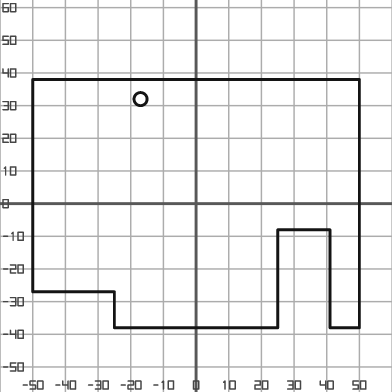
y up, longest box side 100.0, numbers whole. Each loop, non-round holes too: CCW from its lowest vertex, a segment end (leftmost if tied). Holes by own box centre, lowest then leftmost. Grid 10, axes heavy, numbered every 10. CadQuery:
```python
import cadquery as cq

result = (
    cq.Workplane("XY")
    .moveTo(-25.0, -38.0)
    .lineTo(25.0, -38.0)
    .lineTo(25.0, -8.0)
    .lineTo(41.0, -8.0)
    .lineTo(41.0, -38.0)
    .lineTo(50.0, -38.0)
    .lineTo(50.0, 38.0)
    .lineTo(-50.0, 38.0)
    .lineTo(-50.0, -27.0)
    .lineTo(-25.0, -27.0)
    .close()
    .moveTo(-17.0, 32.0)
    .circle(2.0)
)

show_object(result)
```